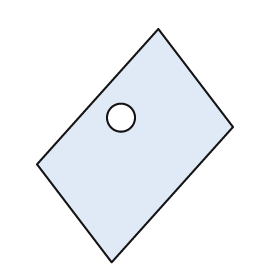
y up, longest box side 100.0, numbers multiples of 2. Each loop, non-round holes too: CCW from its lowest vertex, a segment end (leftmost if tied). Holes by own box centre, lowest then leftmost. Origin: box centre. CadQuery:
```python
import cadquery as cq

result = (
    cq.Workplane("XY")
    .moveTo(-10.0, -50.0)
    .lineTo(42.0, 8.0)
    .lineTo(10.0, 50.0)
    .lineTo(-42.0, -8.0)
    .close()
    .moveTo(-6.0, 12.0)
    .circle(6.0)
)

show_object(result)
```